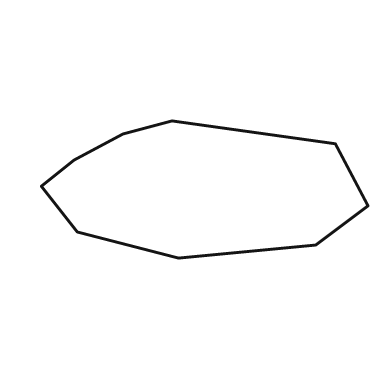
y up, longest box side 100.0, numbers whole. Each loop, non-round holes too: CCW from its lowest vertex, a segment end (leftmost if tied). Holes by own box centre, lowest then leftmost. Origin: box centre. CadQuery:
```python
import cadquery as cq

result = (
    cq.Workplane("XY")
    .moveTo(-8.0, -21.0)
    .lineTo(34.0, -17.0)
    .lineTo(50.0, -5.0)
    .lineTo(40.0, 14.0)
    .lineTo(-10.0, 21.0)
    .lineTo(-25.0, 17.0)
    .lineTo(-40.0, 9.0)
    .lineTo(-50.0, 1.0)
    .lineTo(-39.0, -13.0)
    .close()
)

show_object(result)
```